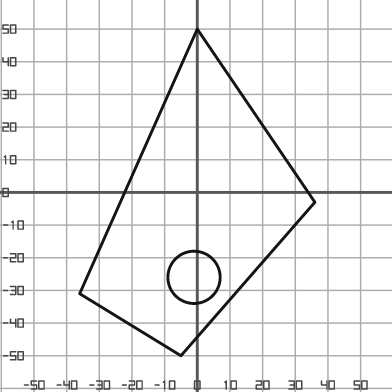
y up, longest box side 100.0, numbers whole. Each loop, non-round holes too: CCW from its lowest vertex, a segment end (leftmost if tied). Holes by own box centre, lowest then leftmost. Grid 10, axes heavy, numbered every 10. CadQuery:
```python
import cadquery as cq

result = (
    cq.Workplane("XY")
    .moveTo(-5.0, -50.0)
    .lineTo(36.0, -3.0)
    .lineTo(0.0, 50.0)
    .lineTo(-36.0, -31.0)
    .close()
    .moveTo(-1.0, -26.0)
    .circle(8.0)
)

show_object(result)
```